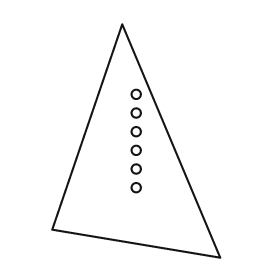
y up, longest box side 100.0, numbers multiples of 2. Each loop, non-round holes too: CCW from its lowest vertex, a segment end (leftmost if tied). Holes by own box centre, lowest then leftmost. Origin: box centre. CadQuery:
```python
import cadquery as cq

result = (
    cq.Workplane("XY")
    .moveTo(36.0, -50.0)
    .lineTo(-6.0, 50.0)
    .lineTo(-36.0, -38.0)
    .close()
    .moveTo(0.0, -20.0)
    .circle(2.0)
    .moveTo(0.0, -12.0)
    .circle(2.0)
    .moveTo(0.0, -4.0)
    .circle(2.0)
    .moveTo(0.0, 4.0)
    .circle(2.0)
    .moveTo(0.0, 12.0)
    .circle(2.0)
    .moveTo(0.0, 20.0)
    .circle(2.0)
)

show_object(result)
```